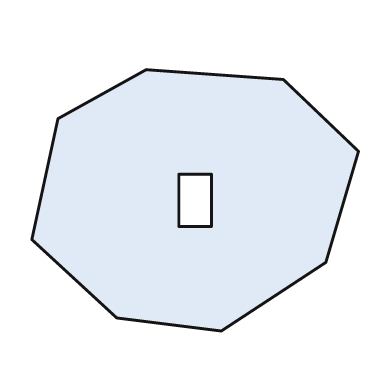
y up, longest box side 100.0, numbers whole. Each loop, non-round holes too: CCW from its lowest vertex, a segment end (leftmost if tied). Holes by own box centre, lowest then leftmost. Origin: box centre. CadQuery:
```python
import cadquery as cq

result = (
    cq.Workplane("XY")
    .moveTo(8.0, -40.0)
    .lineTo(40.0, -19.0)
    .lineTo(50.0, 15.0)
    .lineTo(27.0, 37.0)
    .lineTo(-15.0, 40.0)
    .lineTo(-42.0, 25.0)
    .lineTo(-50.0, -12.0)
    .lineTo(-24.0, -36.0)
    .close()
    .moveTo(-5.0, -8.0)
    .lineTo(5.0, -8.0)
    .lineTo(5.0, 8.0)
    .lineTo(-5.0, 8.0)
    .close()
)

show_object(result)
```